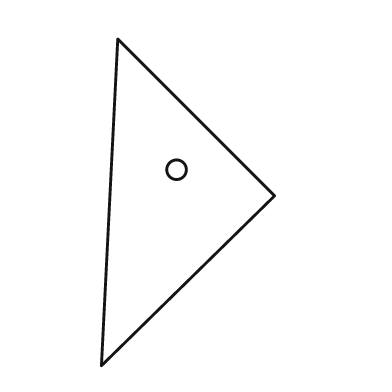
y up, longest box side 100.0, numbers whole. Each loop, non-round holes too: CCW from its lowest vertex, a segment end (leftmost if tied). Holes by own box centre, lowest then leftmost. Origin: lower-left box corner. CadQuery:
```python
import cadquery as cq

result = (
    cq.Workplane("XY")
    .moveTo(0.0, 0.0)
    .lineTo(53.0, 52.0)
    .lineTo(5.0, 100.0)
    .close()
    .moveTo(23.0, 60.0)
    .circle(3.0)
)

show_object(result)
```